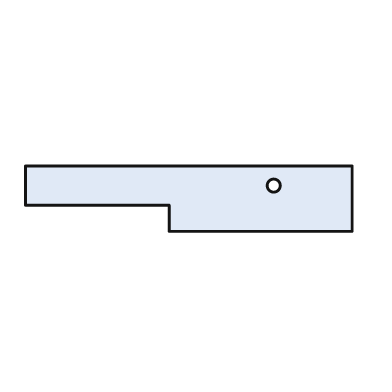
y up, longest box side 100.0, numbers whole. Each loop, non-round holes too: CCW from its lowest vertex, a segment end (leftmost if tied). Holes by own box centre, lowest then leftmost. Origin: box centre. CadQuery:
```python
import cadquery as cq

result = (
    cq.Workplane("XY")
    .moveTo(-6.0, -10.0)
    .lineTo(50.0, -10.0)
    .lineTo(50.0, 10.0)
    .lineTo(-50.0, 10.0)
    .lineTo(-50.0, -2.0)
    .lineTo(-6.0, -2.0)
    .close()
    .moveTo(26.0, 4.0)
    .circle(2.0)
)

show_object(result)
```